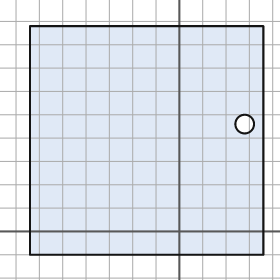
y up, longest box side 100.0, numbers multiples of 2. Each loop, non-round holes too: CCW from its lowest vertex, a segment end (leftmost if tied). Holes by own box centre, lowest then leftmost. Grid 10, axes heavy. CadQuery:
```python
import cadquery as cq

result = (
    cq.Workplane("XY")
    .moveTo(-64.0, -10.0)
    .lineTo(36.0, -10.0)
    .lineTo(36.0, 88.0)
    .lineTo(-64.0, 88.0)
    .close()
    .moveTo(28.0, 46.0)
    .circle(4.0)
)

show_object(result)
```